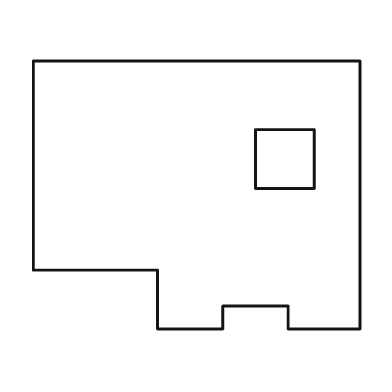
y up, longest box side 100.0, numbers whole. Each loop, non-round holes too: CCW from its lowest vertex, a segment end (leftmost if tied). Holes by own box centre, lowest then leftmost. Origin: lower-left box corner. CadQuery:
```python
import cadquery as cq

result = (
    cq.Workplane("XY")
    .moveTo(38.0, 0.0)
    .lineTo(58.0, 0.0)
    .lineTo(58.0, 7.0)
    .lineTo(78.0, 7.0)
    .lineTo(78.0, 0.0)
    .lineTo(100.0, 0.0)
    .lineTo(100.0, 82.0)
    .lineTo(0.0, 82.0)
    .lineTo(0.0, 18.0)
    .lineTo(38.0, 18.0)
    .close()
    .moveTo(68.0, 43.0)
    .lineTo(86.0, 43.0)
    .lineTo(86.0, 61.0)
    .lineTo(68.0, 61.0)
    .close()
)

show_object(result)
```